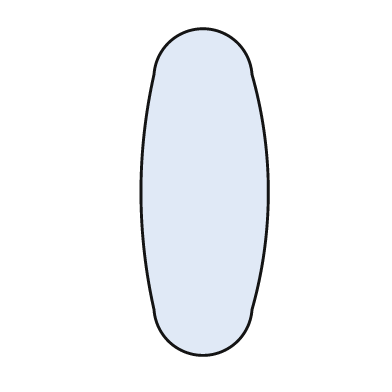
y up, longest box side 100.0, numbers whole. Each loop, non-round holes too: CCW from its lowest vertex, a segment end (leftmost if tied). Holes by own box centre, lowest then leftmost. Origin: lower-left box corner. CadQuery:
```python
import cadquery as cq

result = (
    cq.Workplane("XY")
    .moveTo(4.0, 14.0)
    .threePointArc((19.0, 0.0), (34.0, 14.0))
    .threePointArc((39.0, 50.0), (34.0, 86.0))
    .threePointArc((19.0, 100.0), (4.0, 86.0))
    .threePointArc((0.0, 50.0), (4.0, 14.0))
    .close()
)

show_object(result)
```